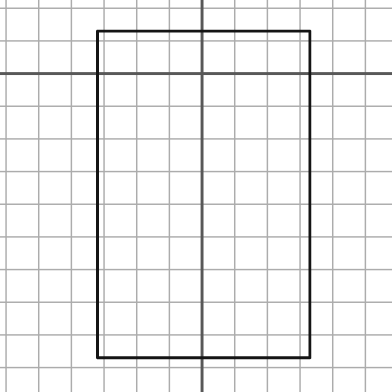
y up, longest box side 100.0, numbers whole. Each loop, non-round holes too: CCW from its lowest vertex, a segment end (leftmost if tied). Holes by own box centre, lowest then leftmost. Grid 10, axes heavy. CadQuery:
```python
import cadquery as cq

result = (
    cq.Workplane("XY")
    .moveTo(-32.0, -87.0)
    .lineTo(33.0, -87.0)
    .lineTo(33.0, 13.0)
    .lineTo(-32.0, 13.0)
    .close()
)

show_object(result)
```